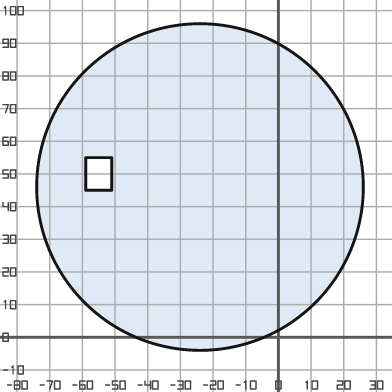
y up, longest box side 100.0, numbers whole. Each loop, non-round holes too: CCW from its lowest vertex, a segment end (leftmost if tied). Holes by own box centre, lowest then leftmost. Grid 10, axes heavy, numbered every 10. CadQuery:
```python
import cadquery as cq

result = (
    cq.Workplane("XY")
    .moveTo(-24.0, 46.0)
    .circle(50.0)
    .moveTo(-59.0, 45.0)
    .lineTo(-51.0, 45.0)
    .lineTo(-51.0, 55.0)
    .lineTo(-59.0, 55.0)
    .close()
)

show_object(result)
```